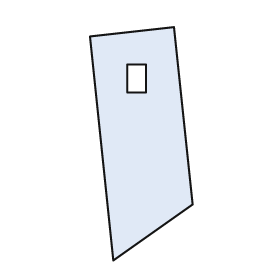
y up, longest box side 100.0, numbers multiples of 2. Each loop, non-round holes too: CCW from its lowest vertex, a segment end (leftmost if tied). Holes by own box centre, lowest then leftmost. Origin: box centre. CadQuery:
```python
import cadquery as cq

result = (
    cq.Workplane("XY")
    .moveTo(-12.0, -50.0)
    .lineTo(22.0, -26.0)
    .lineTo(14.0, 50.0)
    .lineTo(-22.0, 46.0)
    .close()
    .moveTo(-6.0, 22.0)
    .lineTo(2.0, 22.0)
    .lineTo(2.0, 34.0)
    .lineTo(-6.0, 34.0)
    .close()
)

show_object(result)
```